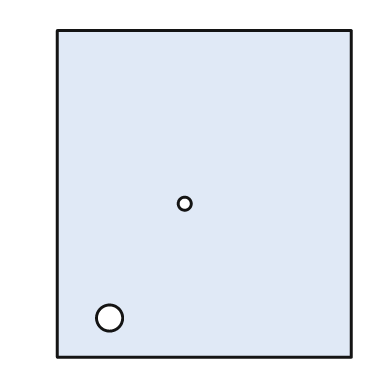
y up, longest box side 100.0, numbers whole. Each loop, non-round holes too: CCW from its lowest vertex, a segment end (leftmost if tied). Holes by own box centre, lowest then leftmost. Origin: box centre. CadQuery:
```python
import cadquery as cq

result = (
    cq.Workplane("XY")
    .moveTo(-45.0, -50.0)
    .lineTo(45.0, -50.0)
    .lineTo(45.0, 50.0)
    .lineTo(-45.0, 50.0)
    .close()
    .moveTo(-29.0, -38.0)
    .circle(4.0)
    .moveTo(-6.0, -3.0)
    .circle(2.0)
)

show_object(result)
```